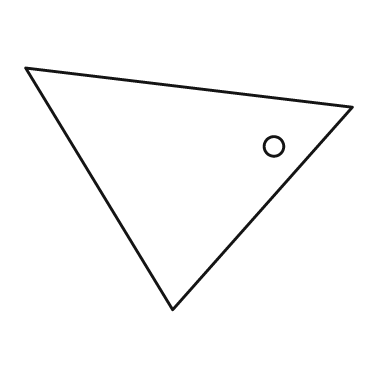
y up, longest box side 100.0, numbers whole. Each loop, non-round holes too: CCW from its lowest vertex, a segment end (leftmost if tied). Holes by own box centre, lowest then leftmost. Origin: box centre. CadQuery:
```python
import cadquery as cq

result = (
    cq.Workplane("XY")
    .moveTo(-5.0, -37.0)
    .lineTo(50.0, 25.0)
    .lineTo(-50.0, 37.0)
    .close()
    .moveTo(26.0, 13.0)
    .circle(3.0)
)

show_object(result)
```